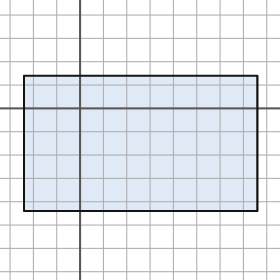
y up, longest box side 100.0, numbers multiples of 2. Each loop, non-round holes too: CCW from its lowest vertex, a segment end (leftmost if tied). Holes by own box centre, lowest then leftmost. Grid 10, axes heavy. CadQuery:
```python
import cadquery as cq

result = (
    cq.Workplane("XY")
    .moveTo(-24.0, -44.0)
    .lineTo(76.0, -44.0)
    .lineTo(76.0, 14.0)
    .lineTo(-24.0, 14.0)
    .close()
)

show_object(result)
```